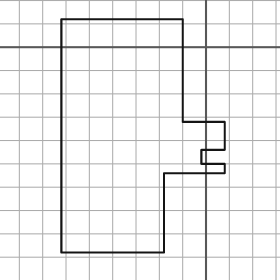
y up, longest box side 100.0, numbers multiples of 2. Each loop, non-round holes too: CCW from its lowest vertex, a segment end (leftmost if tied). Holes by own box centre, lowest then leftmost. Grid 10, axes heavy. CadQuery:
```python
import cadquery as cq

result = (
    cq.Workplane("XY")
    .moveTo(-62.0, -88.0)
    .lineTo(-18.0, -88.0)
    .lineTo(-18.0, -54.0)
    .lineTo(8.0, -54.0)
    .lineTo(8.0, -50.0)
    .lineTo(-2.0, -50.0)
    .lineTo(-2.0, -44.0)
    .lineTo(8.0, -44.0)
    .lineTo(8.0, -32.0)
    .lineTo(-10.0, -32.0)
    .lineTo(-10.0, 12.0)
    .lineTo(-62.0, 12.0)
    .close()
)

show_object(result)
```